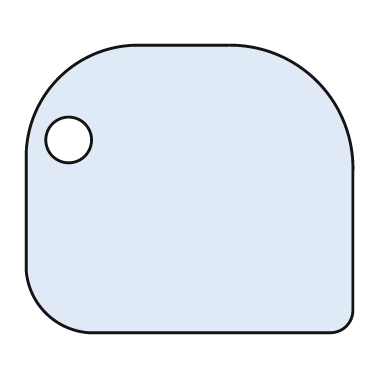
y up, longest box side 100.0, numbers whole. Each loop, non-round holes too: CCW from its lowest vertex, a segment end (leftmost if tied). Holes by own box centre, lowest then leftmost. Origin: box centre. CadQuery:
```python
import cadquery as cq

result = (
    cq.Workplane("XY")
    .moveTo(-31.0, -44.0)
    .lineTo(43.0, -44.0)
    .threePointArc((48.0, -42.0), (50.0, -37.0))
    .lineTo(50.0, 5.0)
    .threePointArc((39.0, 33.0), (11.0, 44.0))
    .lineTo(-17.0, 44.0)
    .threePointArc((-40.0, 34.0), (-50.0, 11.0))
    .lineTo(-50.0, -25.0)
    .threePointArc((-44.0, -38.0), (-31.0, -44.0))
    .close()
    .moveTo(-37.0, 15.0)
    .circle(7.0)
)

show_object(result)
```